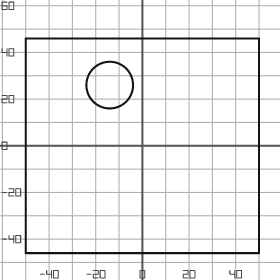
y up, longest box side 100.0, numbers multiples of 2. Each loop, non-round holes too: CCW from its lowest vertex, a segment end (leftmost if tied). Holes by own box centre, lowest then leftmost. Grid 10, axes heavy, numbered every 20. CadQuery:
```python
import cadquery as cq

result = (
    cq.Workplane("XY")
    .moveTo(-50.0, -46.0)
    .lineTo(50.0, -46.0)
    .lineTo(50.0, 46.0)
    .lineTo(-50.0, 46.0)
    .close()
    .moveTo(-14.0, 26.0)
    .circle(10.0)
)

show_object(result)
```